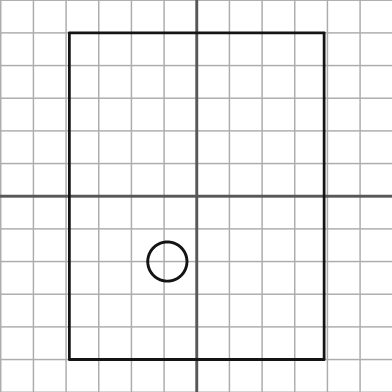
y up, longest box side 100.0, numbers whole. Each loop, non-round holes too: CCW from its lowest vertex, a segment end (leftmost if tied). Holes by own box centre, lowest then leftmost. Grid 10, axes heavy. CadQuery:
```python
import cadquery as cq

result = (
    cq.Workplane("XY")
    .moveTo(-39.0, -50.0)
    .lineTo(39.0, -50.0)
    .lineTo(39.0, 50.0)
    .lineTo(-39.0, 50.0)
    .close()
    .moveTo(-9.0, -20.0)
    .circle(6.0)
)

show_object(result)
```